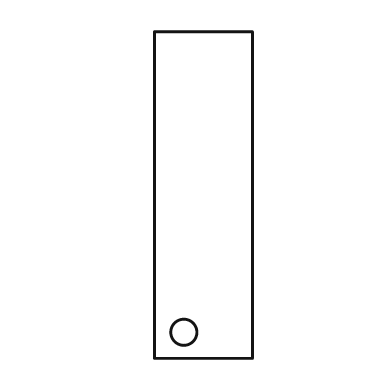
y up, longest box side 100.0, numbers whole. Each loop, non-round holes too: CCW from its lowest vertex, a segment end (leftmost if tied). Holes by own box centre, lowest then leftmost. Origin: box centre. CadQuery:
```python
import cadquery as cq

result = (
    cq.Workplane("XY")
    .moveTo(-15.0, -50.0)
    .lineTo(15.0, -50.0)
    .lineTo(15.0, 50.0)
    .lineTo(-15.0, 50.0)
    .close()
    .moveTo(-6.0, -42.0)
    .circle(4.0)
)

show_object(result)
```